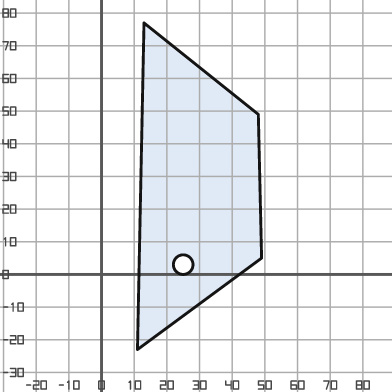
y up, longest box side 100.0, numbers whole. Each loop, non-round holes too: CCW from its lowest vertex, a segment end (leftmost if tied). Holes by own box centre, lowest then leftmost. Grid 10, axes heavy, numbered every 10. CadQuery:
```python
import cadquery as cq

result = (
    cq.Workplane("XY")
    .moveTo(11.0, -23.0)
    .lineTo(49.0, 5.0)
    .lineTo(48.0, 49.0)
    .lineTo(13.0, 77.0)
    .close()
    .moveTo(25.0, 3.0)
    .circle(3.0)
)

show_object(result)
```